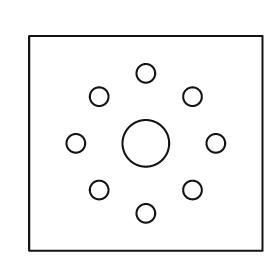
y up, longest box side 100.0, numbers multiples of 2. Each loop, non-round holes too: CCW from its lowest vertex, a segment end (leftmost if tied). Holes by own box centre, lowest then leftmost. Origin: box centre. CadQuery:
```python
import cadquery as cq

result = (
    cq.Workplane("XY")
    .moveTo(-50.0, -46.0)
    .lineTo(50.0, -46.0)
    .lineTo(50.0, 46.0)
    .lineTo(-50.0, 46.0)
    .close()
    .moveTo(0.0, -30.0)
    .circle(4.0)
    .moveTo(-20.0, -20.0)
    .circle(4.0)
    .moveTo(20.0, -20.0)
    .circle(4.0)
    .moveTo(-30.0, 0.0)
    .circle(4.0)
    .moveTo(0.0, 0.0)
    .circle(10.0)
    .moveTo(30.0, 0.0)
    .circle(4.0)
    .moveTo(-20.0, 20.0)
    .circle(4.0)
    .moveTo(20.0, 20.0)
    .circle(4.0)
    .moveTo(0.0, 30.0)
    .circle(4.0)
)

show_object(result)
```